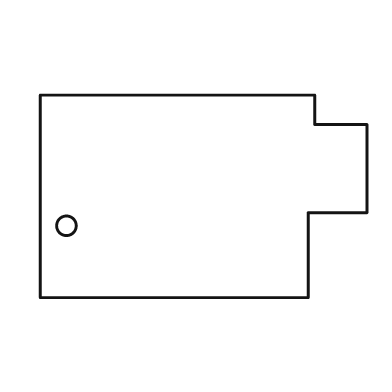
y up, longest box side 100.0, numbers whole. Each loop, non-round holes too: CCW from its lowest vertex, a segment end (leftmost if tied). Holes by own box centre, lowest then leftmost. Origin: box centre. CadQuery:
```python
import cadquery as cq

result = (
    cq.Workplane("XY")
    .moveTo(-50.0, -31.0)
    .lineTo(32.0, -31.0)
    .lineTo(32.0, -5.0)
    .lineTo(50.0, -5.0)
    .lineTo(50.0, 22.0)
    .lineTo(34.0, 22.0)
    .lineTo(34.0, 31.0)
    .lineTo(-50.0, 31.0)
    .close()
    .moveTo(-42.0, -9.0)
    .circle(3.0)
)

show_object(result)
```